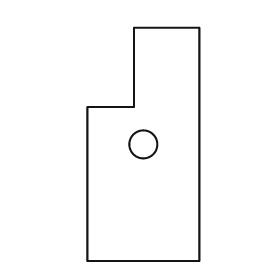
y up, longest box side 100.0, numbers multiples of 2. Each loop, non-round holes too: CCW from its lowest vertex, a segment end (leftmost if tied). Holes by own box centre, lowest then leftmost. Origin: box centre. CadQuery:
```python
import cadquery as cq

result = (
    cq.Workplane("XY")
    .moveTo(-24.0, -50.0)
    .lineTo(24.0, -50.0)
    .lineTo(24.0, 50.0)
    .lineTo(-4.0, 50.0)
    .lineTo(-4.0, 16.0)
    .lineTo(-24.0, 16.0)
    .close()
    .moveTo(0.0, 0.0)
    .circle(6.0)
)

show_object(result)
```